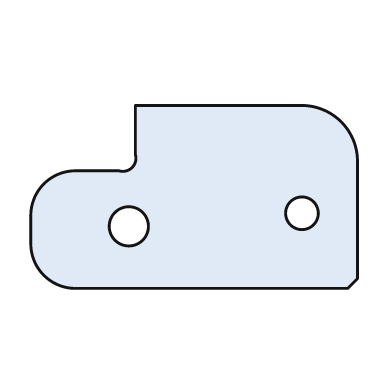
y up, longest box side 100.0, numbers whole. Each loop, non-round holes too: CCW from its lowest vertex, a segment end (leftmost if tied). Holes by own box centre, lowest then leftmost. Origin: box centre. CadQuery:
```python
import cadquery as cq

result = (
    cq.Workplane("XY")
    .moveTo(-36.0, -28.0)
    .lineTo(47.0, -28.0)
    .lineTo(50.0, -25.0)
    .lineTo(50.0, 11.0)
    .threePointArc((45.0, 23.0), (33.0, 28.0))
    .lineTo(-18.0, 28.0)
    .lineTo(-18.0, 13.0)
    .threePointArc((-19.0, 9.0), (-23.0, 8.0))
    .lineTo(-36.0, 8.0)
    .threePointArc((-46.0, 4.0), (-50.0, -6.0))
    .lineTo(-50.0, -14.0)
    .threePointArc((-46.0, -24.0), (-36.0, -28.0))
    .close()
    .moveTo(-20.0, -9.0)
    .circle(6.0)
    .moveTo(33.0, -5.0)
    .circle(5.0)
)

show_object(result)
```